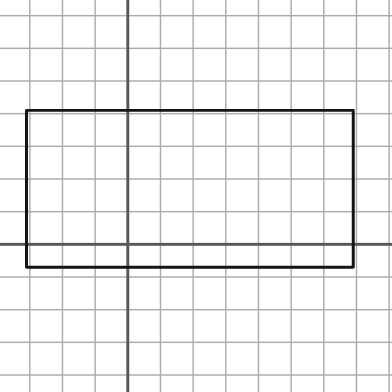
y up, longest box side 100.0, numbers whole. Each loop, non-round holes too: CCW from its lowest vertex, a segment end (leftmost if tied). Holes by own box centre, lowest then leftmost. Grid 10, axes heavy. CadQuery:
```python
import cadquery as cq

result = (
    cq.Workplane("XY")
    .moveTo(-31.0, -7.0)
    .lineTo(69.0, -7.0)
    .lineTo(69.0, 41.0)
    .lineTo(-31.0, 41.0)
    .close()
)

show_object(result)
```